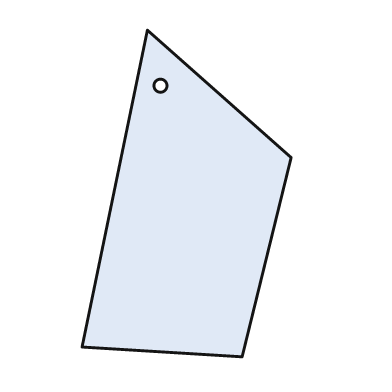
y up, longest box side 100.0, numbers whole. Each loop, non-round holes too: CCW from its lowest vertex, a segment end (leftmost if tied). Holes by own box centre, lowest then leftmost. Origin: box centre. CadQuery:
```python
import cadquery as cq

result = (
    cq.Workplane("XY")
    .moveTo(17.0, -50.0)
    .lineTo(32.0, 11.0)
    .lineTo(-12.0, 50.0)
    .lineTo(-32.0, -47.0)
    .close()
    .moveTo(-8.0, 33.0)
    .circle(2.0)
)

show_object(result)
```